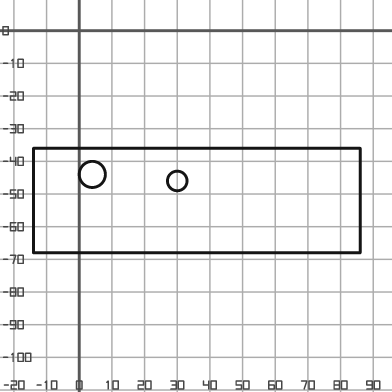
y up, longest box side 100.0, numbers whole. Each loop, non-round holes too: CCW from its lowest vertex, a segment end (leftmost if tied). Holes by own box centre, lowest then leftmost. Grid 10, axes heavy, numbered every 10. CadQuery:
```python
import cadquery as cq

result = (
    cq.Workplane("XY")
    .moveTo(-14.0, -68.0)
    .lineTo(86.0, -68.0)
    .lineTo(86.0, -36.0)
    .lineTo(-14.0, -36.0)
    .close()
    .moveTo(30.0, -46.0)
    .circle(3.0)
    .moveTo(4.0, -44.0)
    .circle(4.0)
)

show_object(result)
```